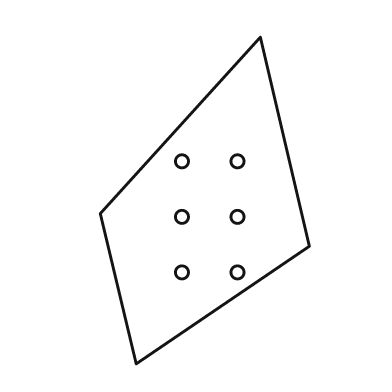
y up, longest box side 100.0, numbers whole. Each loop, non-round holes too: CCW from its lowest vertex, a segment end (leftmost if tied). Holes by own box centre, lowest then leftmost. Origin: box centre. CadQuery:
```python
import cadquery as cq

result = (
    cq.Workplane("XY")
    .moveTo(-21.0, -50.0)
    .lineTo(32.0, -14.0)
    .lineTo(17.0, 50.0)
    .lineTo(-32.0, -4.0)
    .close()
    .moveTo(-7.0, -22.0)
    .circle(2.0)
    .moveTo(10.0, -22.0)
    .circle(2.0)
    .moveTo(-7.0, -5.0)
    .circle(2.0)
    .moveTo(10.0, -5.0)
    .circle(2.0)
    .moveTo(-7.0, 12.0)
    .circle(2.0)
    .moveTo(10.0, 12.0)
    .circle(2.0)
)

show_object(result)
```